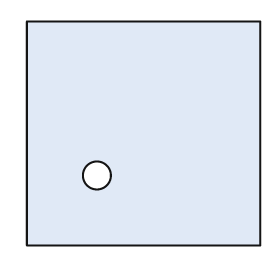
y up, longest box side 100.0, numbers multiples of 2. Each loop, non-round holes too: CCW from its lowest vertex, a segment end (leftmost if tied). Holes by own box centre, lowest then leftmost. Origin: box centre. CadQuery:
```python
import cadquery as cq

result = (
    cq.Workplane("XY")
    .moveTo(-50.0, -48.0)
    .lineTo(50.0, -48.0)
    .lineTo(50.0, 48.0)
    .lineTo(-50.0, 48.0)
    .close()
    .moveTo(-20.0, -18.0)
    .circle(6.0)
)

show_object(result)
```